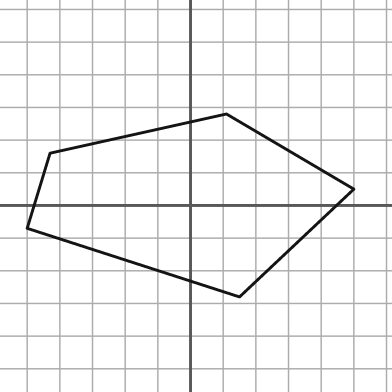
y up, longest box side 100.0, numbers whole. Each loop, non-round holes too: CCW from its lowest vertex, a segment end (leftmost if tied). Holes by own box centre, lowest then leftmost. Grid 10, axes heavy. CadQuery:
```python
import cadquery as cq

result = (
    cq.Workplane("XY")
    .moveTo(15.0, -28.0)
    .lineTo(50.0, 5.0)
    .lineTo(11.0, 28.0)
    .lineTo(-43.0, 16.0)
    .lineTo(-50.0, -7.0)
    .close()
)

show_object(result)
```